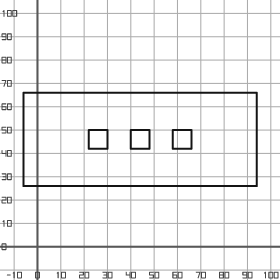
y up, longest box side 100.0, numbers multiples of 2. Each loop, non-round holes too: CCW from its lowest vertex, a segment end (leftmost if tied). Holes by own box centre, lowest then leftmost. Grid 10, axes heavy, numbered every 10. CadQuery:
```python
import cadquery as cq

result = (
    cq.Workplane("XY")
    .moveTo(-6.0, 26.0)
    .lineTo(94.0, 26.0)
    .lineTo(94.0, 66.0)
    .lineTo(-6.0, 66.0)
    .close()
    .moveTo(22.0, 42.0)
    .lineTo(30.0, 42.0)
    .lineTo(30.0, 50.0)
    .lineTo(22.0, 50.0)
    .close()
    .moveTo(40.0, 42.0)
    .lineTo(48.0, 42.0)
    .lineTo(48.0, 50.0)
    .lineTo(40.0, 50.0)
    .close()
    .moveTo(58.0, 42.0)
    .lineTo(66.0, 42.0)
    .lineTo(66.0, 50.0)
    .lineTo(58.0, 50.0)
    .close()
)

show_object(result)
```